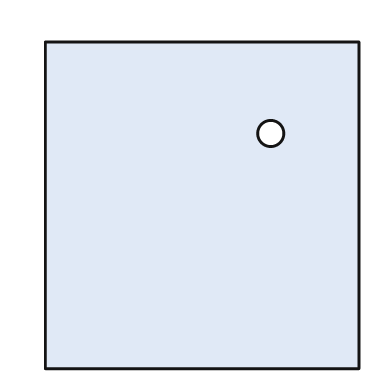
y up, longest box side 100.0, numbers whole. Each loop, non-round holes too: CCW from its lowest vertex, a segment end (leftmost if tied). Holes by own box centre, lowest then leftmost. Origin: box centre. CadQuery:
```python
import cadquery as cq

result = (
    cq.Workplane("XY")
    .moveTo(-48.0, -50.0)
    .lineTo(48.0, -50.0)
    .lineTo(48.0, 50.0)
    .lineTo(-48.0, 50.0)
    .close()
    .moveTo(21.0, 22.0)
    .circle(4.0)
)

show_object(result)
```